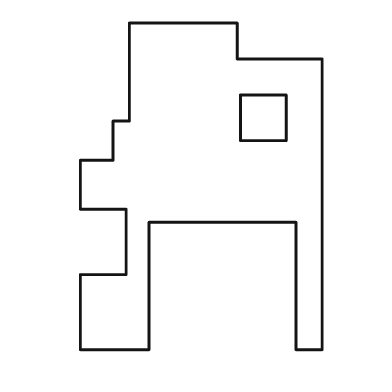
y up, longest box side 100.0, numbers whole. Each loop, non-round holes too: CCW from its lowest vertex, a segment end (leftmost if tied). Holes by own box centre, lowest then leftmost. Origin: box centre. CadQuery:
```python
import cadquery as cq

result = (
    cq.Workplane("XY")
    .moveTo(-37.0, -50.0)
    .lineTo(-16.0, -50.0)
    .lineTo(-16.0, -11.0)
    .lineTo(29.0, -11.0)
    .lineTo(29.0, -50.0)
    .lineTo(37.0, -50.0)
    .lineTo(37.0, 39.0)
    .lineTo(11.0, 39.0)
    .lineTo(11.0, 50.0)
    .lineTo(-22.0, 50.0)
    .lineTo(-22.0, 20.0)
    .lineTo(-27.0, 20.0)
    .lineTo(-27.0, 8.0)
    .lineTo(-37.0, 8.0)
    .lineTo(-37.0, -7.0)
    .lineTo(-23.0, -7.0)
    .lineTo(-23.0, -27.0)
    .lineTo(-37.0, -27.0)
    .close()
    .moveTo(12.0, 14.0)
    .lineTo(26.0, 14.0)
    .lineTo(26.0, 28.0)
    .lineTo(12.0, 28.0)
    .close()
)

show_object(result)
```